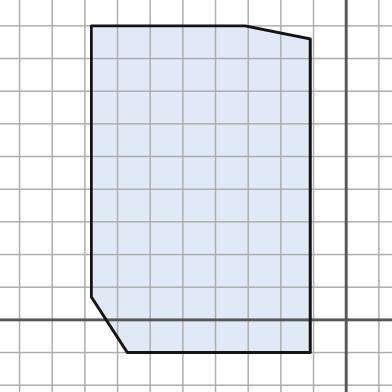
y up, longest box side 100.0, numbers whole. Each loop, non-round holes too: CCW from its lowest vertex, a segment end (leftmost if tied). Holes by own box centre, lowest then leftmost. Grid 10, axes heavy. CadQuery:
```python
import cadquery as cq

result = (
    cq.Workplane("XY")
    .moveTo(-67.0, -10.0)
    .lineTo(-11.0, -10.0)
    .lineTo(-11.0, 86.0)
    .lineTo(-31.0, 90.0)
    .lineTo(-78.0, 90.0)
    .lineTo(-78.0, 7.0)
    .close()
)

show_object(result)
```